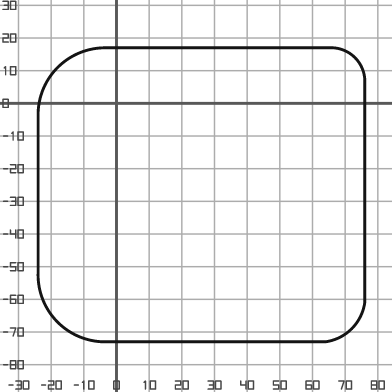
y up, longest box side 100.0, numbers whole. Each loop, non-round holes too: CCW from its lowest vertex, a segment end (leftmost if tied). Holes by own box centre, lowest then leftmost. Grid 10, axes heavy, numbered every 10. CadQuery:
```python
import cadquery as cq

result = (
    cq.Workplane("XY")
    .moveTo(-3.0, -73.0)
    .lineTo(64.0, -73.0)
    .threePointArc((72.0, -69.0), (76.0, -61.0))
    .lineTo(76.0, 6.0)
    .threePointArc((73.0, 14.0), (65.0, 17.0))
    .lineTo(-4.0, 17.0)
    .threePointArc((-18.0, 11.0), (-24.0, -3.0))
    .lineTo(-24.0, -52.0)
    .threePointArc((-18.0, -67.0), (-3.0, -73.0))
    .close()
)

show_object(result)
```